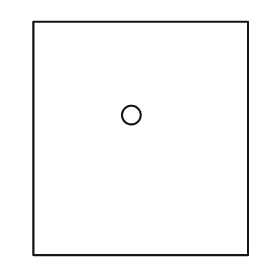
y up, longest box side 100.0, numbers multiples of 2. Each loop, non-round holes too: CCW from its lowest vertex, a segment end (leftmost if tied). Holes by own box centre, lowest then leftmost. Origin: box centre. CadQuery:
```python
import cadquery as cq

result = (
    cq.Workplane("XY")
    .moveTo(-46.0, -50.0)
    .lineTo(46.0, -50.0)
    .lineTo(46.0, 50.0)
    .lineTo(-46.0, 50.0)
    .close()
    .moveTo(-4.0, 10.0)
    .circle(4.0)
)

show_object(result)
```